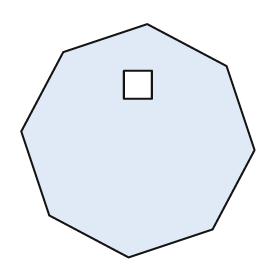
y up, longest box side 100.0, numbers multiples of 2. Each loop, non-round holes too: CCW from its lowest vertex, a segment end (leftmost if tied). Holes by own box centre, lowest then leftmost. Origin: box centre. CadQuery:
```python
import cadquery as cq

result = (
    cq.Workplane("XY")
    .moveTo(-4.0, -50.0)
    .lineTo(32.0, -38.0)
    .lineTo(50.0, -4.0)
    .lineTo(38.0, 32.0)
    .lineTo(4.0, 50.0)
    .lineTo(-32.0, 38.0)
    .lineTo(-50.0, 4.0)
    .lineTo(-38.0, -32.0)
    .close()
    .moveTo(-6.0, 18.0)
    .lineTo(6.0, 18.0)
    .lineTo(6.0, 30.0)
    .lineTo(-6.0, 30.0)
    .close()
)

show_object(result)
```